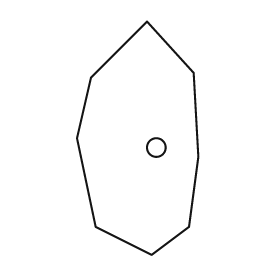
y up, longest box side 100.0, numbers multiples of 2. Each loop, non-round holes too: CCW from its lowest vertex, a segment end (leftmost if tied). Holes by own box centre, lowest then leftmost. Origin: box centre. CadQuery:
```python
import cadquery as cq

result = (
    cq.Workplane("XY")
    .moveTo(6.0, -50.0)
    .lineTo(22.0, -38.0)
    .lineTo(26.0, -8.0)
    .lineTo(24.0, 28.0)
    .lineTo(4.0, 50.0)
    .lineTo(-20.0, 26.0)
    .lineTo(-26.0, 0.0)
    .lineTo(-18.0, -38.0)
    .close()
    .moveTo(8.0, -4.0)
    .circle(4.0)
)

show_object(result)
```